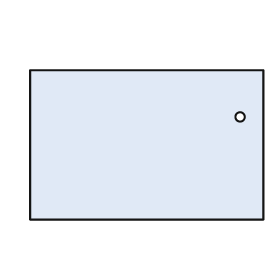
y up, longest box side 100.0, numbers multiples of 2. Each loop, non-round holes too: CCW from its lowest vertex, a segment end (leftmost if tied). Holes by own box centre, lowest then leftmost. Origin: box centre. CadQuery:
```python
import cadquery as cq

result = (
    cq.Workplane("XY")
    .moveTo(-50.0, -32.0)
    .lineTo(50.0, -32.0)
    .lineTo(50.0, 32.0)
    .lineTo(-50.0, 32.0)
    .close()
    .moveTo(40.0, 12.0)
    .circle(2.0)
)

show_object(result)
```